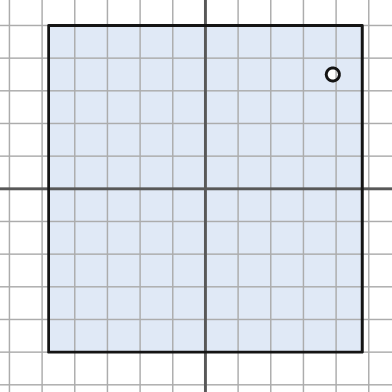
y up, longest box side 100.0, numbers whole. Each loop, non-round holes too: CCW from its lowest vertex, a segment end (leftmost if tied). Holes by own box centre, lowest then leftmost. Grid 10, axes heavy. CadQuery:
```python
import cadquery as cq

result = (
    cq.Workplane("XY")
    .moveTo(-48.0, -50.0)
    .lineTo(48.0, -50.0)
    .lineTo(48.0, 50.0)
    .lineTo(-48.0, 50.0)
    .close()
    .moveTo(39.0, 35.0)
    .circle(2.0)
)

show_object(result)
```